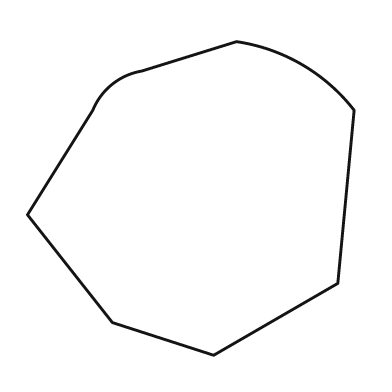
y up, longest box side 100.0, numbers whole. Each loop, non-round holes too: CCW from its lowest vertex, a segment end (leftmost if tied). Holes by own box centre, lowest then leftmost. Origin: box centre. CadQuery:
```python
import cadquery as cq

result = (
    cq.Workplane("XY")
    .moveTo(7.0, -48.0)
    .lineTo(45.0, -26.0)
    .lineTo(50.0, 27.0)
    .threePointArc((34.0, 41.0), (14.0, 48.0))
    .lineTo(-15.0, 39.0)
    .threePointArc((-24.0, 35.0), (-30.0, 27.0))
    .lineTo(-50.0, -5.0)
    .lineTo(-24.0, -38.0)
    .close()
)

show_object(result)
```